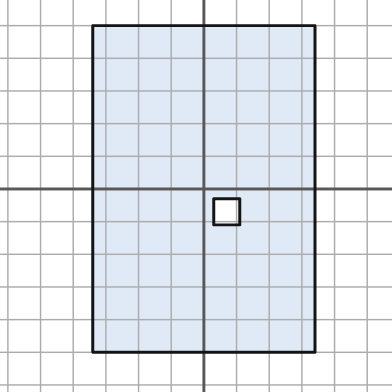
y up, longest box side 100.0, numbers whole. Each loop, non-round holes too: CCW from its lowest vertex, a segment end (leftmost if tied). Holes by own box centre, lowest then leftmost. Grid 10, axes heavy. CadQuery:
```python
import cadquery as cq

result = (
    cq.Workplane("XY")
    .moveTo(-34.0, -50.0)
    .lineTo(34.0, -50.0)
    .lineTo(34.0, 50.0)
    .lineTo(-34.0, 50.0)
    .close()
    .moveTo(3.0, -11.0)
    .lineTo(11.0, -11.0)
    .lineTo(11.0, -3.0)
    .lineTo(3.0, -3.0)
    .close()
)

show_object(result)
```